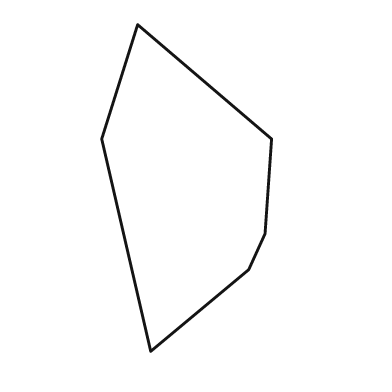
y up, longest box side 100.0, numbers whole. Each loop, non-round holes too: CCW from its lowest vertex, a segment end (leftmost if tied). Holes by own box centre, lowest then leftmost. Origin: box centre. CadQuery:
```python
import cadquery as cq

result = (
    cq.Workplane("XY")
    .moveTo(-11.0, -50.0)
    .lineTo(19.0, -25.0)
    .lineTo(24.0, -14.0)
    .lineTo(26.0, 15.0)
    .lineTo(-15.0, 50.0)
    .lineTo(-26.0, 15.0)
    .close()
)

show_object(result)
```